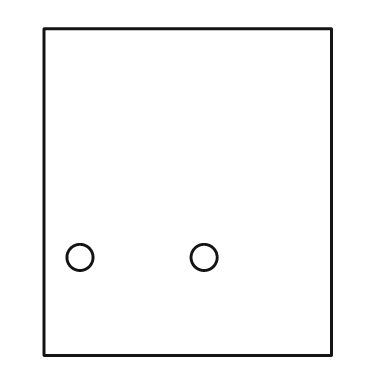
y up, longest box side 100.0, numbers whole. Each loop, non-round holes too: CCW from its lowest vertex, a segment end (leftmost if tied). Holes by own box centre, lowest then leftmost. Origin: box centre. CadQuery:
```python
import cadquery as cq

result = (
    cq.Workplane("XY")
    .moveTo(-44.0, -50.0)
    .lineTo(44.0, -50.0)
    .lineTo(44.0, 50.0)
    .lineTo(-44.0, 50.0)
    .close()
    .moveTo(-33.0, -20.0)
    .circle(4.0)
    .moveTo(5.0, -20.0)
    .circle(4.0)
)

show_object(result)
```